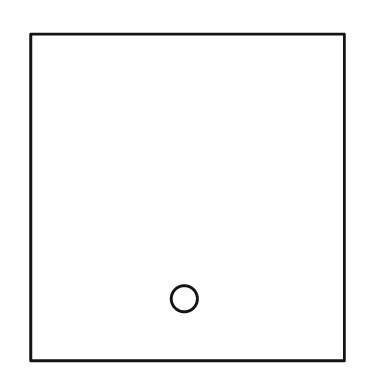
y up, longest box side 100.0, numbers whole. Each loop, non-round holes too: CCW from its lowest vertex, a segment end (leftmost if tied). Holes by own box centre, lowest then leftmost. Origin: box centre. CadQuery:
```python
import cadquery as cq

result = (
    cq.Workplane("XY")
    .moveTo(-48.0, -50.0)
    .lineTo(48.0, -50.0)
    .lineTo(48.0, 50.0)
    .lineTo(-48.0, 50.0)
    .close()
    .moveTo(-1.0, -31.0)
    .circle(4.0)
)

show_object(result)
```